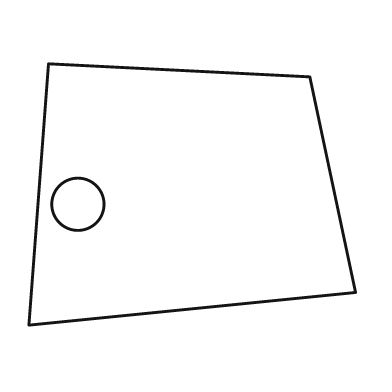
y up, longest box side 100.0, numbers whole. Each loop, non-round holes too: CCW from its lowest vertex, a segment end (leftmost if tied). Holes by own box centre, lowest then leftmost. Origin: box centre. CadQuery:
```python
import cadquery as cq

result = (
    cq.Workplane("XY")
    .moveTo(-50.0, -40.0)
    .lineTo(50.0, -30.0)
    .lineTo(36.0, 36.0)
    .lineTo(-44.0, 40.0)
    .close()
    .moveTo(-35.0, -3.0)
    .circle(8.0)
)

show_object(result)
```